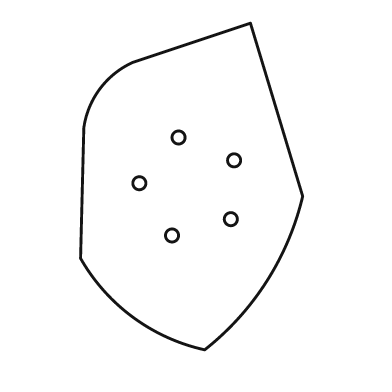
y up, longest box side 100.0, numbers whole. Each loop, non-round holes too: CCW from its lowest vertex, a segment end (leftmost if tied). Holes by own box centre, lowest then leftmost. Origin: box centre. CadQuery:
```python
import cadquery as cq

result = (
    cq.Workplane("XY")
    .moveTo(4.0, -50.0)
    .threePointArc((23.0, -29.0), (34.0, -3.0))
    .lineTo(18.0, 50.0)
    .lineTo(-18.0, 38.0)
    .threePointArc((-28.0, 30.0), (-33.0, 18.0))
    .lineTo(-34.0, -22.0)
    .threePointArc((-18.0, -40.0), (4.0, -50.0))
    .close()
    .moveTo(-6.0, -15.0)
    .circle(2.0)
    .moveTo(12.0, -10.0)
    .circle(2.0)
    .moveTo(-16.0, 1.0)
    .circle(2.0)
    .moveTo(13.0, 8.0)
    .circle(2.0)
    .moveTo(-4.0, 15.0)
    .circle(2.0)
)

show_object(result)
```